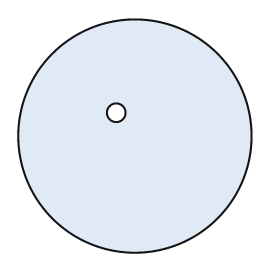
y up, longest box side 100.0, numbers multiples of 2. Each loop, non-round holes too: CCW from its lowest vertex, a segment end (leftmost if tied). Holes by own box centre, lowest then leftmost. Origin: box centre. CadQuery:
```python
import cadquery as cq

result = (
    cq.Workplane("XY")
    .moveTo(0.0, 0.0)
    .circle(50.0)
    .moveTo(-8.0, 10.0)
    .circle(4.0)
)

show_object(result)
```